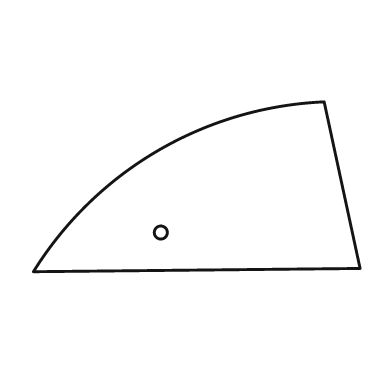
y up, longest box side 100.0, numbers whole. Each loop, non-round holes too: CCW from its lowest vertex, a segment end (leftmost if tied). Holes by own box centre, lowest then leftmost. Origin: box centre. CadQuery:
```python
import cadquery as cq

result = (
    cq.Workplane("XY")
    .moveTo(-50.0, -26.0)
    .lineTo(50.0, -25.0)
    .lineTo(39.0, 26.0)
    .threePointArc((-12.0, 11.0), (-50.0, -26.0))
    .close()
    .moveTo(-11.0, -14.0)
    .circle(2.0)
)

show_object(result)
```